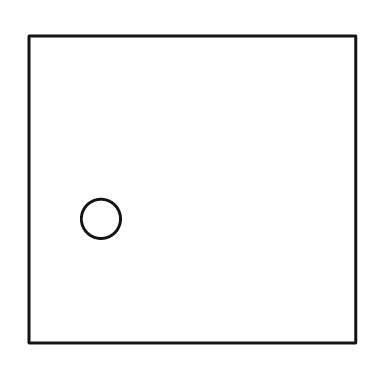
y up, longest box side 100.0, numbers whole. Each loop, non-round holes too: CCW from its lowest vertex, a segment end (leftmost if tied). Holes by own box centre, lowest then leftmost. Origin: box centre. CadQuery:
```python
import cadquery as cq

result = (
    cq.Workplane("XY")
    .moveTo(-50.0, -47.0)
    .lineTo(50.0, -47.0)
    .lineTo(50.0, 47.0)
    .lineTo(-50.0, 47.0)
    .close()
    .moveTo(-28.0, -9.0)
    .circle(6.0)
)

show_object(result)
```